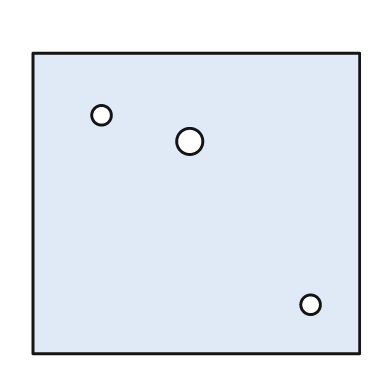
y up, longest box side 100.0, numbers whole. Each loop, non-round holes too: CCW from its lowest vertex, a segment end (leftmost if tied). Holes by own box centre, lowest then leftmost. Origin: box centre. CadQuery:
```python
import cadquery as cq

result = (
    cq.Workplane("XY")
    .moveTo(-50.0, -46.0)
    .lineTo(50.0, -46.0)
    .lineTo(50.0, 46.0)
    .lineTo(-50.0, 46.0)
    .close()
    .moveTo(35.0, -31.0)
    .circle(3.0)
    .moveTo(-2.0, 19.0)
    .circle(4.0)
    .moveTo(-29.0, 27.0)
    .circle(3.0)
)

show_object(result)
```